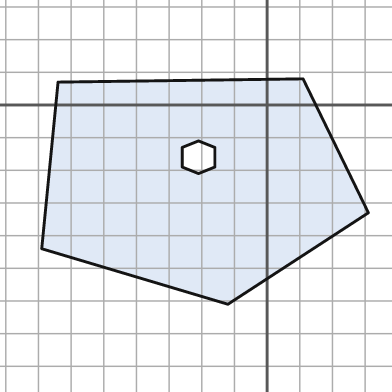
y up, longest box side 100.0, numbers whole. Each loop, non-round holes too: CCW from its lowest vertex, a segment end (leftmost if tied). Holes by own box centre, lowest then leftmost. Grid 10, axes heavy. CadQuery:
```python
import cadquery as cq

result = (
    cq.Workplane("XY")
    .moveTo(-12.0, -61.0)
    .lineTo(31.0, -33.0)
    .lineTo(11.0, 8.0)
    .lineTo(-64.0, 7.0)
    .lineTo(-69.0, -44.0)
    .close()
    .moveTo(-21.0, -21.0)
    .lineTo(-16.0, -19.0)
    .lineTo(-16.0, -13.0)
    .lineTo(-21.0, -11.0)
    .lineTo(-26.0, -13.0)
    .lineTo(-26.0, -19.0)
    .close()
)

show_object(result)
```